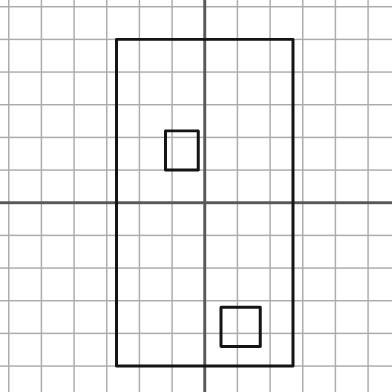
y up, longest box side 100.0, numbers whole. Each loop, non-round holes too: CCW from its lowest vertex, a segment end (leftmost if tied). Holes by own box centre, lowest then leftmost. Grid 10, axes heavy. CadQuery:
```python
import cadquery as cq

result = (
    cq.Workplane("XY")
    .moveTo(-27.0, -50.0)
    .lineTo(27.0, -50.0)
    .lineTo(27.0, 50.0)
    .lineTo(-27.0, 50.0)
    .close()
    .moveTo(5.0, -44.0)
    .lineTo(17.0, -44.0)
    .lineTo(17.0, -32.0)
    .lineTo(5.0, -32.0)
    .close()
    .moveTo(-12.0, 10.0)
    .lineTo(-2.0, 10.0)
    .lineTo(-2.0, 22.0)
    .lineTo(-12.0, 22.0)
    .close()
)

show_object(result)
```